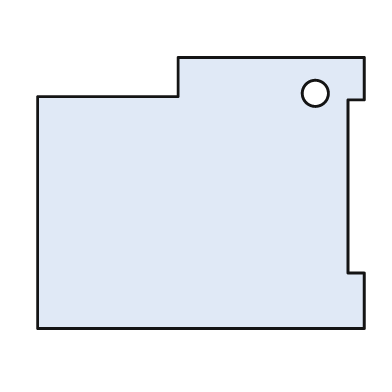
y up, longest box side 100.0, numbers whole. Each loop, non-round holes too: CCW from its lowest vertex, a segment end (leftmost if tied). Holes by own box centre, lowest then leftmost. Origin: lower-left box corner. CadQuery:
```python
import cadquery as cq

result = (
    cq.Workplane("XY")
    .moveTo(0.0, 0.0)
    .lineTo(100.0, 0.0)
    .lineTo(100.0, 17.0)
    .lineTo(95.0, 17.0)
    .lineTo(95.0, 70.0)
    .lineTo(100.0, 70.0)
    .lineTo(100.0, 83.0)
    .lineTo(43.0, 83.0)
    .lineTo(43.0, 71.0)
    .lineTo(0.0, 71.0)
    .close()
    .moveTo(85.0, 72.0)
    .circle(4.0)
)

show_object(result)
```